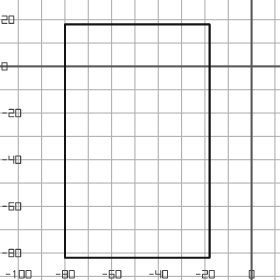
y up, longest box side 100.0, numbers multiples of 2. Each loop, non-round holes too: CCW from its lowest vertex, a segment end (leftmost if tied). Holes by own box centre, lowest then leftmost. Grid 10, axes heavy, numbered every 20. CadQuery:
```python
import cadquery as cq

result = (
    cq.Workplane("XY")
    .moveTo(-80.0, -82.0)
    .lineTo(-18.0, -82.0)
    .lineTo(-18.0, 18.0)
    .lineTo(-80.0, 18.0)
    .close()
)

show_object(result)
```